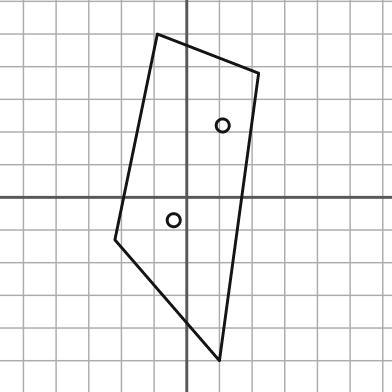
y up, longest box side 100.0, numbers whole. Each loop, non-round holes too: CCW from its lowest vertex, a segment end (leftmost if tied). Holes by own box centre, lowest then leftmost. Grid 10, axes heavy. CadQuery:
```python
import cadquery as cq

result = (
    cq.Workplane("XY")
    .moveTo(10.0, -50.0)
    .lineTo(22.0, 38.0)
    .lineTo(-9.0, 50.0)
    .lineTo(-22.0, -13.0)
    .close()
    .moveTo(-4.0, -7.0)
    .circle(2.0)
    .moveTo(11.0, 22.0)
    .circle(2.0)
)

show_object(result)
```